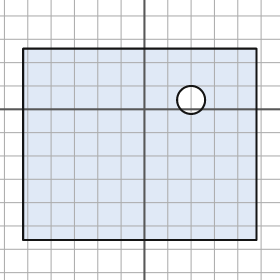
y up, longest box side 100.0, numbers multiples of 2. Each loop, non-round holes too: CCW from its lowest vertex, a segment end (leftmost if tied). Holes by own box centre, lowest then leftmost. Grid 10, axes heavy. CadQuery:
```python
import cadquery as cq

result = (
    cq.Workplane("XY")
    .moveTo(-52.0, -56.0)
    .lineTo(48.0, -56.0)
    .lineTo(48.0, 26.0)
    .lineTo(-52.0, 26.0)
    .close()
    .moveTo(20.0, 4.0)
    .circle(6.0)
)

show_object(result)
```